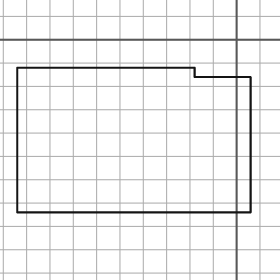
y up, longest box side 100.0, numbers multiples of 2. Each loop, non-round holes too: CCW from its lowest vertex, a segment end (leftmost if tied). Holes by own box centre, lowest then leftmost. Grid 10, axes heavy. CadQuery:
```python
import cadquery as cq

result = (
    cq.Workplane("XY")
    .moveTo(-94.0, -74.0)
    .lineTo(6.0, -74.0)
    .lineTo(6.0, -16.0)
    .lineTo(-18.0, -16.0)
    .lineTo(-18.0, -12.0)
    .lineTo(-94.0, -12.0)
    .close()
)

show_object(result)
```